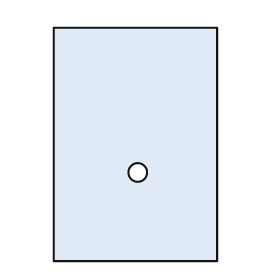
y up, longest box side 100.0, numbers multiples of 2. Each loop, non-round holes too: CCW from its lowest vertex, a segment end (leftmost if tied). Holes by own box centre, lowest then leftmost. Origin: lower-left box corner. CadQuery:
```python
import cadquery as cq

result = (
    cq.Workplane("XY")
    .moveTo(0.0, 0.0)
    .lineTo(70.0, 0.0)
    .lineTo(70.0, 100.0)
    .lineTo(0.0, 100.0)
    .close()
    .moveTo(36.0, 38.0)
    .circle(4.0)
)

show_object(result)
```